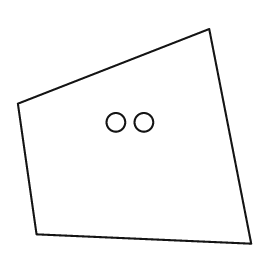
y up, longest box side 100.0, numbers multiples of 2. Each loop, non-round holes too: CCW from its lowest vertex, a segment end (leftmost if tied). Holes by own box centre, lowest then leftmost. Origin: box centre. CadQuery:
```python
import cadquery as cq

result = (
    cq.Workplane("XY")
    .moveTo(50.0, -46.0)
    .lineTo(32.0, 46.0)
    .lineTo(-50.0, 14.0)
    .lineTo(-42.0, -42.0)
    .close()
    .moveTo(-8.0, 6.0)
    .circle(4.0)
    .moveTo(4.0, 6.0)
    .circle(4.0)
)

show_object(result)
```